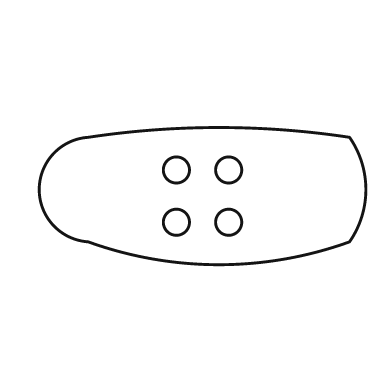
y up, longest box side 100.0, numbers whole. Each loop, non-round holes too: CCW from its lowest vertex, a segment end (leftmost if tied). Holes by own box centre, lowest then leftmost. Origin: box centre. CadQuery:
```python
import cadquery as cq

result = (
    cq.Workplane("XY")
    .moveTo(-35.0, -14.0)
    .threePointArc((5.0, -21.0), (45.0, -14.0))
    .threePointArc((50.0, 2.0), (45.0, 18.0))
    .threePointArc((5.0, 21.0), (-35.0, 18.0))
    .threePointArc((-50.0, 2.0), (-35.0, -14.0))
    .close()
    .moveTo(-8.0, -8.0)
    .circle(4.0)
    .moveTo(8.0, -8.0)
    .circle(4.0)
    .moveTo(-8.0, 8.0)
    .circle(4.0)
    .moveTo(8.0, 8.0)
    .circle(4.0)
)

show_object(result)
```